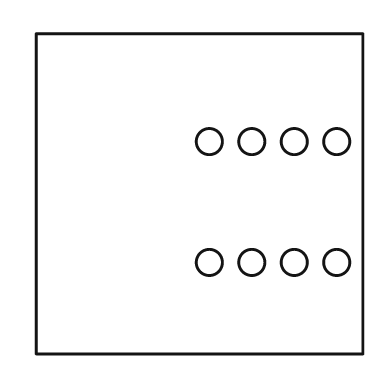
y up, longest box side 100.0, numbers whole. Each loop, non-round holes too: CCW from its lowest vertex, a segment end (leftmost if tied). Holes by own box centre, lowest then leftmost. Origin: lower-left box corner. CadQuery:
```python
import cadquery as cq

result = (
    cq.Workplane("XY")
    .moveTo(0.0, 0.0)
    .lineTo(100.0, 0.0)
    .lineTo(100.0, 98.0)
    .lineTo(0.0, 98.0)
    .close()
    .moveTo(53.0, 28.0)
    .circle(4.0)
    .moveTo(66.0, 28.0)
    .circle(4.0)
    .moveTo(79.0, 28.0)
    .circle(4.0)
    .moveTo(92.0, 28.0)
    .circle(4.0)
    .moveTo(53.0, 65.0)
    .circle(4.0)
    .moveTo(66.0, 65.0)
    .circle(4.0)
    .moveTo(79.0, 65.0)
    .circle(4.0)
    .moveTo(92.0, 65.0)
    .circle(4.0)
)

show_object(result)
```